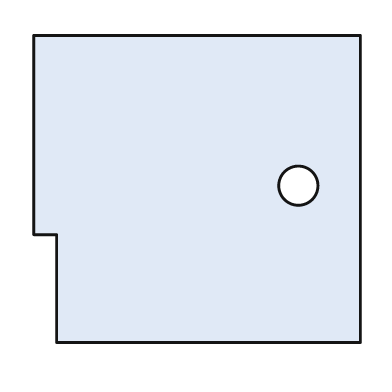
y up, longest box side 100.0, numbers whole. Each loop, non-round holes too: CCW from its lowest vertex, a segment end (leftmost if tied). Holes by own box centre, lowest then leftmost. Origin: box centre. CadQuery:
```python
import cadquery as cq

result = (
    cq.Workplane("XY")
    .moveTo(-43.0, -47.0)
    .lineTo(50.0, -47.0)
    .lineTo(50.0, 47.0)
    .lineTo(-50.0, 47.0)
    .lineTo(-50.0, -14.0)
    .lineTo(-43.0, -14.0)
    .close()
    .moveTo(31.0, 1.0)
    .circle(6.0)
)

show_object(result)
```